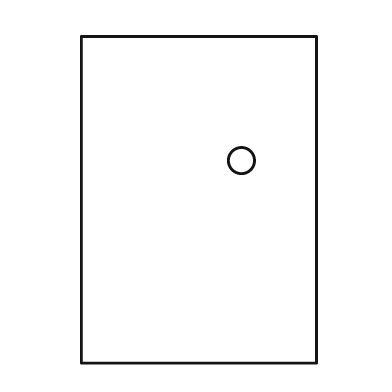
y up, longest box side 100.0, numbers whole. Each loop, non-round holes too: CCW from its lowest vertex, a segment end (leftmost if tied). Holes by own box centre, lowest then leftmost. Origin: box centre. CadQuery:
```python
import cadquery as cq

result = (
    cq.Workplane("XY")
    .moveTo(-36.0, -50.0)
    .lineTo(36.0, -50.0)
    .lineTo(36.0, 50.0)
    .lineTo(-36.0, 50.0)
    .close()
    .moveTo(13.0, 12.0)
    .circle(4.0)
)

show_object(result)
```